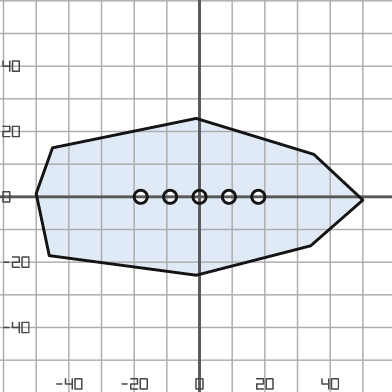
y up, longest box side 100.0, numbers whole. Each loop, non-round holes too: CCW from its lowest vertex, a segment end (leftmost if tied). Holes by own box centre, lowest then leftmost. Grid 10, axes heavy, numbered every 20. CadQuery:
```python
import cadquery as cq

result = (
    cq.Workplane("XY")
    .moveTo(-1.0, -24.0)
    .lineTo(34.0, -15.0)
    .lineTo(50.0, -1.0)
    .lineTo(35.0, 13.0)
    .lineTo(-1.0, 24.0)
    .lineTo(-45.0, 15.0)
    .lineTo(-50.0, 1.0)
    .lineTo(-46.0, -18.0)
    .close()
    .moveTo(-18.0, 0.0)
    .circle(2.0)
    .moveTo(-9.0, 0.0)
    .circle(2.0)
    .moveTo(0.0, 0.0)
    .circle(2.0)
    .moveTo(9.0, 0.0)
    .circle(2.0)
    .moveTo(18.0, 0.0)
    .circle(2.0)
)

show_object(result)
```